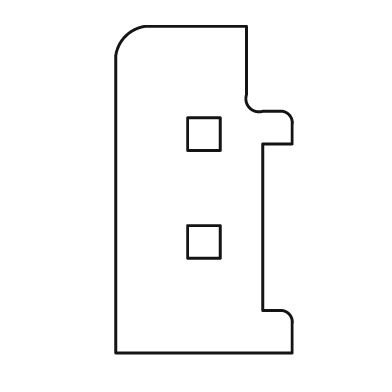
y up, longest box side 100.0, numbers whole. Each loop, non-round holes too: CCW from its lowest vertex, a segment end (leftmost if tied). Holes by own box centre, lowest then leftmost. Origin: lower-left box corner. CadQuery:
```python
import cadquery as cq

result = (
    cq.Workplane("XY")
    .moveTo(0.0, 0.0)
    .lineTo(54.0, 0.0)
    .lineTo(54.0, 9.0)
    .threePointArc((53.0, 12.0), (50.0, 13.0))
    .lineTo(45.0, 13.0)
    .lineTo(45.0, 64.0)
    .lineTo(54.0, 64.0)
    .lineTo(54.0, 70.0)
    .threePointArc((53.0, 73.0), (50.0, 74.0))
    .lineTo(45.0, 74.0)
    .threePointArc((41.0, 75.0), (40.0, 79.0))
    .lineTo(40.0, 100.0)
    .lineTo(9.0, 100.0)
    .threePointArc((3.0, 97.0), (0.0, 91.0))
    .close()
    .moveTo(22.0, 29.0)
    .lineTo(32.0, 29.0)
    .lineTo(32.0, 39.0)
    .lineTo(22.0, 39.0)
    .close()
    .moveTo(22.0, 62.0)
    .lineTo(32.0, 62.0)
    .lineTo(32.0, 72.0)
    .lineTo(22.0, 72.0)
    .close()
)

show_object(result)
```